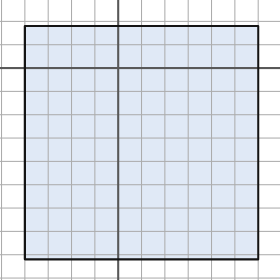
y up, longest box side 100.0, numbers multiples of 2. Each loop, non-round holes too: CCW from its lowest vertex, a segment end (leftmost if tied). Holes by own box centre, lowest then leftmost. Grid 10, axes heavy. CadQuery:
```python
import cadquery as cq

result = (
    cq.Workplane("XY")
    .moveTo(-40.0, -82.0)
    .lineTo(60.0, -82.0)
    .lineTo(60.0, 18.0)
    .lineTo(-40.0, 18.0)
    .close()
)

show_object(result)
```